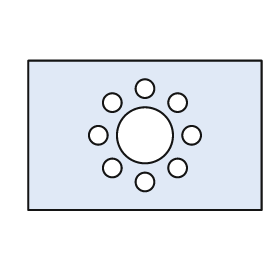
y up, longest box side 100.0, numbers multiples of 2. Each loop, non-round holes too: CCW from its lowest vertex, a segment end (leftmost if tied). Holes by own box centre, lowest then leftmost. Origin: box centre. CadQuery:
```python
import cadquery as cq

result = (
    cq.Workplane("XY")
    .moveTo(-50.0, -32.0)
    .lineTo(50.0, -32.0)
    .lineTo(50.0, 32.0)
    .lineTo(-50.0, 32.0)
    .close()
    .moveTo(0.0, -20.0)
    .circle(4.0)
    .moveTo(-14.0, -14.0)
    .circle(4.0)
    .moveTo(14.0, -14.0)
    .circle(4.0)
    .moveTo(-20.0, 0.0)
    .circle(4.0)
    .moveTo(0.0, 0.0)
    .circle(12.0)
    .moveTo(20.0, 0.0)
    .circle(4.0)
    .moveTo(-14.0, 14.0)
    .circle(4.0)
    .moveTo(14.0, 14.0)
    .circle(4.0)
    .moveTo(0.0, 20.0)
    .circle(4.0)
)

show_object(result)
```